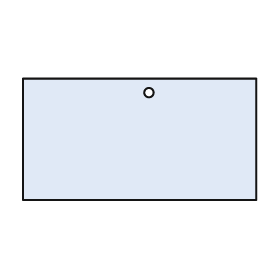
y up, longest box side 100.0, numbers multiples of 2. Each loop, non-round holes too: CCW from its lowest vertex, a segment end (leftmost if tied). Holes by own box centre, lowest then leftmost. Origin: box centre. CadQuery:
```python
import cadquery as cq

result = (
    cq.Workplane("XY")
    .moveTo(-50.0, -26.0)
    .lineTo(50.0, -26.0)
    .lineTo(50.0, 26.0)
    .lineTo(-50.0, 26.0)
    .close()
    .moveTo(4.0, 20.0)
    .circle(2.0)
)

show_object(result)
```